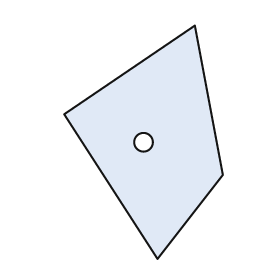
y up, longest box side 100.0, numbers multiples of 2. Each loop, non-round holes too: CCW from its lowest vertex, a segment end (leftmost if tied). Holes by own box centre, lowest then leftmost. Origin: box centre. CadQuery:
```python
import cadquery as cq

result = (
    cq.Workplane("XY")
    .moveTo(6.0, -50.0)
    .lineTo(34.0, -14.0)
    .lineTo(22.0, 50.0)
    .lineTo(-34.0, 12.0)
    .close()
    .moveTo(0.0, 0.0)
    .circle(4.0)
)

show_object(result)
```